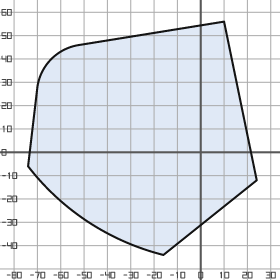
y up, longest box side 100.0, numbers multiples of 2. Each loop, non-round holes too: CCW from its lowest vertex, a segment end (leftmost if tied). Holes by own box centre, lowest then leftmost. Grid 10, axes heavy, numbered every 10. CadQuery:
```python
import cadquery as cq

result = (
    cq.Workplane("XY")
    .moveTo(-16.0, -44.0)
    .lineTo(24.0, -12.0)
    .lineTo(10.0, 56.0)
    .lineTo(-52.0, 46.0)
    .threePointArc((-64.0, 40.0), (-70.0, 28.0))
    .lineTo(-74.0, -6.0)
    .threePointArc((-48.0, -30.0), (-16.0, -44.0))
    .close()
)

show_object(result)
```